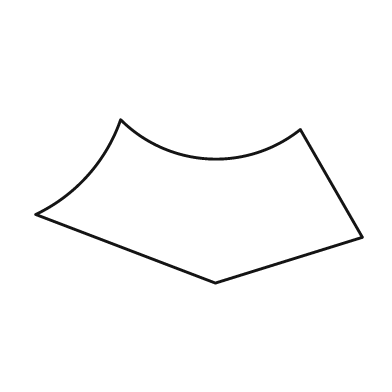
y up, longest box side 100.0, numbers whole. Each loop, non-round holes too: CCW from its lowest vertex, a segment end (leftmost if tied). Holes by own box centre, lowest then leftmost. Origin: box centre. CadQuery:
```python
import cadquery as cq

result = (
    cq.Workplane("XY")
    .moveTo(5.0, -25.0)
    .lineTo(50.0, -11.0)
    .lineTo(31.0, 22.0)
    .threePointArc((3.0, 13.0), (-24.0, 25.0))
    .threePointArc((-34.0, 8.0), (-50.0, -4.0))
    .close()
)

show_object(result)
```